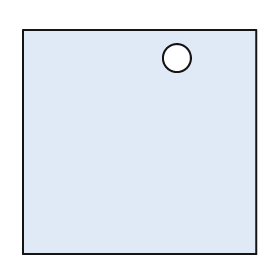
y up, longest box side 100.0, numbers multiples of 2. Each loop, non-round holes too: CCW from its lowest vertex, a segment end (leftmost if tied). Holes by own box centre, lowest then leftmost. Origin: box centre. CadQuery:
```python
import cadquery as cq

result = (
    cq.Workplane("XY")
    .moveTo(-50.0, -48.0)
    .lineTo(50.0, -48.0)
    .lineTo(50.0, 48.0)
    .lineTo(-50.0, 48.0)
    .close()
    .moveTo(16.0, 36.0)
    .circle(6.0)
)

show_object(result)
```